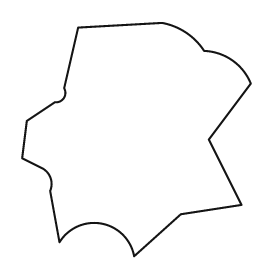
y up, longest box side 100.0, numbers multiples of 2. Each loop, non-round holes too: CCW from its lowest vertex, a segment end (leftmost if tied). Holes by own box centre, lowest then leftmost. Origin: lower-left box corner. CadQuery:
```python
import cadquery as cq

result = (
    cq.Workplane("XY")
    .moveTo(48.0, 0.0)
    .lineTo(68.0, 18.0)
    .lineTo(94.0, 22.0)
    .lineTo(80.0, 50.0)
    .lineTo(98.0, 74.0)
    .threePointArc((90.0, 84.0), (78.0, 88.0))
    .threePointArc((70.0, 96.0), (60.0, 100.0))
    .lineTo(24.0, 98.0)
    .lineTo(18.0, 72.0)
    .threePointArc((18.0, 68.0), (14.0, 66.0))
    .lineTo(2.0, 58.0)
    .lineTo(0.0, 42.0)
    .lineTo(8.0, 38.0)
    .threePointArc((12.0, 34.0), (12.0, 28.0))
    .lineTo(16.0, 6.0)
    .threePointArc((34.0, 14.0), (48.0, 0.0))
    .close()
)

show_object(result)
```